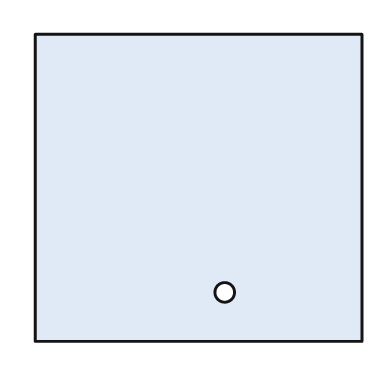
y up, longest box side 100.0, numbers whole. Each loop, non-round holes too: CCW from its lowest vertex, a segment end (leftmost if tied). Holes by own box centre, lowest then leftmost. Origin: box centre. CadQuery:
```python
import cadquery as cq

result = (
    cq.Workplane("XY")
    .moveTo(-50.0, -47.0)
    .lineTo(50.0, -47.0)
    .lineTo(50.0, 47.0)
    .lineTo(-50.0, 47.0)
    .close()
    .moveTo(8.0, -32.0)
    .circle(3.0)
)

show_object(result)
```